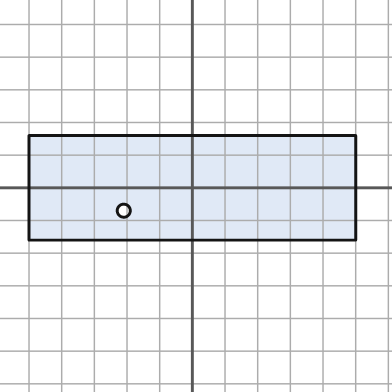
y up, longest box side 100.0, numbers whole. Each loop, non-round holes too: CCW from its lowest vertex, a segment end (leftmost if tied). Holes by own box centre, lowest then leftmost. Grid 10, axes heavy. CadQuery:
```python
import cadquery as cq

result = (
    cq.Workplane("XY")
    .moveTo(-50.0, -16.0)
    .lineTo(50.0, -16.0)
    .lineTo(50.0, 16.0)
    .lineTo(-50.0, 16.0)
    .close()
    .moveTo(-21.0, -7.0)
    .circle(2.0)
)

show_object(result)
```